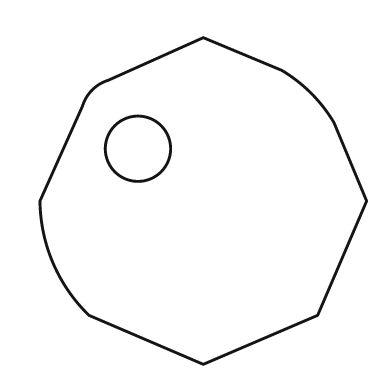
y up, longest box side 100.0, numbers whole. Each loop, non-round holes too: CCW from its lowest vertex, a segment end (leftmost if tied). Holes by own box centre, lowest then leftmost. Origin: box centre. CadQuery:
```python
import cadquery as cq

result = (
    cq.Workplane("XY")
    .moveTo(0.0, -50.0)
    .lineTo(35.0, -35.0)
    .lineTo(50.0, 0.0)
    .lineTo(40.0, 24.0)
    .threePointArc((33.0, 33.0), (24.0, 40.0))
    .lineTo(0.0, 50.0)
    .lineTo(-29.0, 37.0)
    .threePointArc((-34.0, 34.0), (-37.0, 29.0))
    .lineTo(-50.0, 0.0)
    .threePointArc((-46.0, -19.0), (-35.0, -35.0))
    .close()
    .moveTo(-20.0, 16.0)
    .circle(10.0)
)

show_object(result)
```